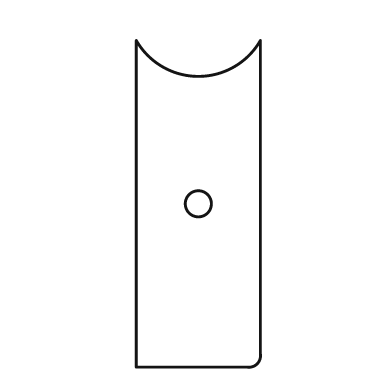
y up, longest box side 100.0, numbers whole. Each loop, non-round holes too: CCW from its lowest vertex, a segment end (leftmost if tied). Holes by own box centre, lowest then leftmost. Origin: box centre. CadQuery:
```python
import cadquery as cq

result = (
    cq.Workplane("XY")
    .moveTo(-19.0, -50.0)
    .lineTo(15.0, -50.0)
    .threePointArc((18.0, -49.0), (19.0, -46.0))
    .lineTo(19.0, 50.0)
    .threePointArc((0.0, 39.0), (-19.0, 50.0))
    .close()
    .moveTo(0.0, 0.0)
    .circle(4.0)
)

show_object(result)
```